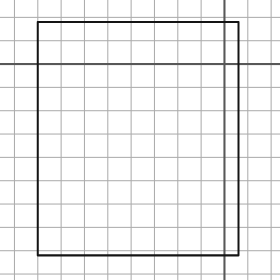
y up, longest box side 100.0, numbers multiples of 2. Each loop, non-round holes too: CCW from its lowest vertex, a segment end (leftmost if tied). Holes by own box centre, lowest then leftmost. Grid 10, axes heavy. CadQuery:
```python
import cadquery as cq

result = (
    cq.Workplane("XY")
    .moveTo(-80.0, -82.0)
    .lineTo(6.0, -82.0)
    .lineTo(6.0, 18.0)
    .lineTo(-80.0, 18.0)
    .close()
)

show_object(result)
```